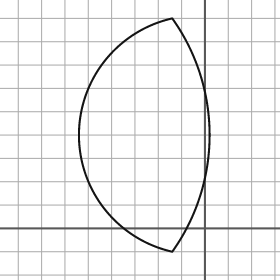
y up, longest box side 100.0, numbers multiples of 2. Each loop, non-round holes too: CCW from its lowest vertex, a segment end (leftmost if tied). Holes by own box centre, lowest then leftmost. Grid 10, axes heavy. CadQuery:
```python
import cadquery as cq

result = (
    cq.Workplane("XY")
    .moveTo(-14.0, -10.0)
    .threePointArc((2.0, 40.0), (-14.0, 90.0))
    .threePointArc((-54.0, 40.0), (-14.0, -10.0))
    .close()
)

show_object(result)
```